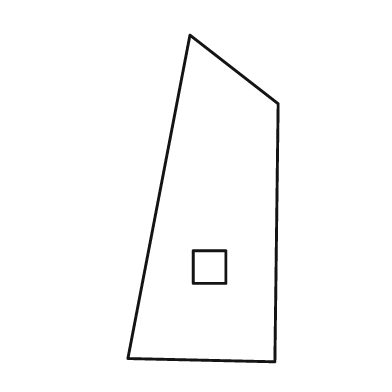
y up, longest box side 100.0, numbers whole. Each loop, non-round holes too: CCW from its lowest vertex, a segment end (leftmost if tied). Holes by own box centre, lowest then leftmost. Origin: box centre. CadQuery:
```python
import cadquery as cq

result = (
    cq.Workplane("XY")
    .moveTo(22.0, -50.0)
    .lineTo(23.0, 29.0)
    .lineTo(-4.0, 50.0)
    .lineTo(-23.0, -49.0)
    .close()
    .moveTo(-3.0, -26.0)
    .lineTo(7.0, -26.0)
    .lineTo(7.0, -16.0)
    .lineTo(-3.0, -16.0)
    .close()
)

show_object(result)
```